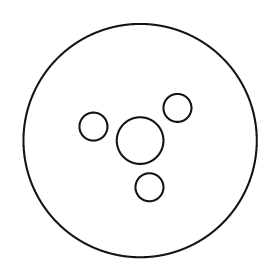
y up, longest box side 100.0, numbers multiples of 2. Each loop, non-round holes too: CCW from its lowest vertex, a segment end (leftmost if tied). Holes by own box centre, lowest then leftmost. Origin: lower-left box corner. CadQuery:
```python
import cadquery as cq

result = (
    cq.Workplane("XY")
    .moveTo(50.0, 50.0)
    .circle(50.0)
    .moveTo(54.0, 30.0)
    .circle(6.0)
    .moveTo(50.0, 50.0)
    .circle(10.0)
    .moveTo(30.0, 56.0)
    .circle(6.0)
    .moveTo(66.0, 64.0)
    .circle(6.0)
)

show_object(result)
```